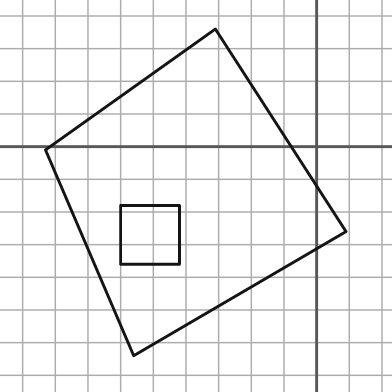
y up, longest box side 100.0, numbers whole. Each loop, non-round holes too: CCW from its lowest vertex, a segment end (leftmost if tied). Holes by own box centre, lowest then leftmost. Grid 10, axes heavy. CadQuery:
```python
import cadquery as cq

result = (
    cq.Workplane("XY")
    .moveTo(-56.0, -64.0)
    .lineTo(9.0, -26.0)
    .lineTo(-31.0, 36.0)
    .lineTo(-83.0, -1.0)
    .close()
    .moveTo(-60.0, -36.0)
    .lineTo(-42.0, -36.0)
    .lineTo(-42.0, -18.0)
    .lineTo(-60.0, -18.0)
    .close()
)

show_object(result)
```